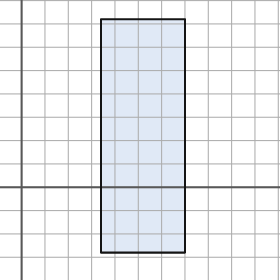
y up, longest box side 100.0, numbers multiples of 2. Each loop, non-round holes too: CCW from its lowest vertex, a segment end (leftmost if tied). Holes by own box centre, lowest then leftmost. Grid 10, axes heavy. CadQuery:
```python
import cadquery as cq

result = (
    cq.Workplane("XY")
    .moveTo(34.0, -28.0)
    .lineTo(70.0, -28.0)
    .lineTo(70.0, 72.0)
    .lineTo(34.0, 72.0)
    .close()
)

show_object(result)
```